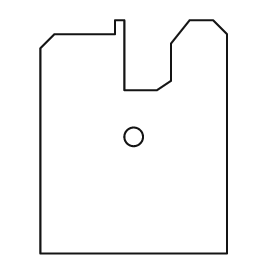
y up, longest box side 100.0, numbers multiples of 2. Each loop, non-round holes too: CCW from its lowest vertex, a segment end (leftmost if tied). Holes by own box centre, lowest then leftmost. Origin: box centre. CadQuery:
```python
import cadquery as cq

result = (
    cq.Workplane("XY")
    .moveTo(-40.0, -50.0)
    .lineTo(40.0, -50.0)
    .lineTo(40.0, 44.0)
    .lineTo(34.0, 50.0)
    .lineTo(24.0, 50.0)
    .lineTo(16.0, 40.0)
    .lineTo(16.0, 24.0)
    .lineTo(10.0, 20.0)
    .lineTo(-4.0, 20.0)
    .lineTo(-4.0, 50.0)
    .lineTo(-8.0, 50.0)
    .lineTo(-8.0, 44.0)
    .lineTo(-34.0, 44.0)
    .lineTo(-40.0, 38.0)
    .close()
    .moveTo(0.0, 0.0)
    .circle(4.0)
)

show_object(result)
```